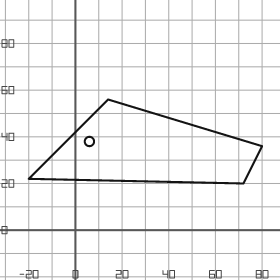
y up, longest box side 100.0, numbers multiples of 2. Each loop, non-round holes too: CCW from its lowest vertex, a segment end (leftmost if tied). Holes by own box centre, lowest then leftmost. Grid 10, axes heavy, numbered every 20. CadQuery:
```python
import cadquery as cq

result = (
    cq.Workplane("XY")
    .moveTo(72.0, 20.0)
    .lineTo(80.0, 36.0)
    .lineTo(14.0, 56.0)
    .lineTo(-20.0, 22.0)
    .close()
    .moveTo(6.0, 38.0)
    .circle(2.0)
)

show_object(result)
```